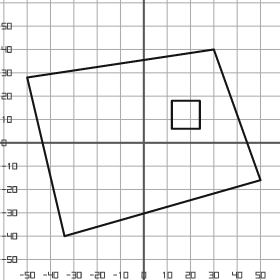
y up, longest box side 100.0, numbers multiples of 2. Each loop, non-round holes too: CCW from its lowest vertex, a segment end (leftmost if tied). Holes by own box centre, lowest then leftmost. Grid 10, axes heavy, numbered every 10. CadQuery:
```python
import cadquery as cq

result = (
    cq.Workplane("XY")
    .moveTo(-34.0, -40.0)
    .lineTo(50.0, -16.0)
    .lineTo(30.0, 40.0)
    .lineTo(-50.0, 28.0)
    .close()
    .moveTo(12.0, 6.0)
    .lineTo(24.0, 6.0)
    .lineTo(24.0, 18.0)
    .lineTo(12.0, 18.0)
    .close()
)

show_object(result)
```